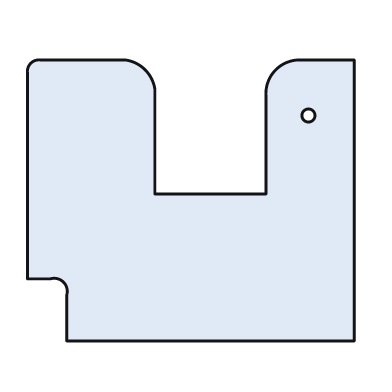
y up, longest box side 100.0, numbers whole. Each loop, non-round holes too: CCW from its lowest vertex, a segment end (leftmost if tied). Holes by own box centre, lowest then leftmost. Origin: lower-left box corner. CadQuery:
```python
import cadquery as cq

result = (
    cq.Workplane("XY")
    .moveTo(12.0, 0.0)
    .lineTo(100.0, 0.0)
    .lineTo(100.0, 86.0)
    .lineTo(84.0, 86.0)
    .threePointArc((76.0, 83.0), (73.0, 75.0))
    .lineTo(73.0, 45.0)
    .lineTo(39.0, 45.0)
    .lineTo(39.0, 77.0)
    .threePointArc((36.0, 83.0), (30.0, 86.0))
    .lineTo(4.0, 86.0)
    .threePointArc((1.0, 85.0), (0.0, 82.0))
    .lineTo(0.0, 19.0)
    .lineTo(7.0, 19.0)
    .threePointArc((11.0, 18.0), (12.0, 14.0))
    .close()
    .moveTo(86.0, 69.0)
    .circle(2.0)
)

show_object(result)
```